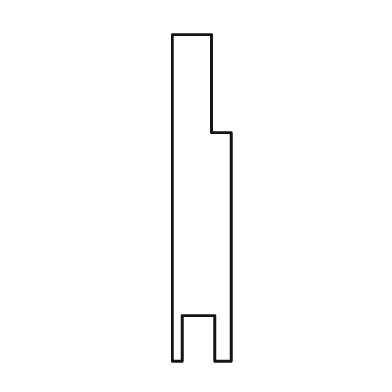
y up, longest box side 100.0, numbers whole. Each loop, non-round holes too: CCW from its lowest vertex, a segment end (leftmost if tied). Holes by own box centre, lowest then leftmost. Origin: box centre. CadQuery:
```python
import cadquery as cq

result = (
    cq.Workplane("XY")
    .moveTo(-9.0, -50.0)
    .lineTo(-6.0, -50.0)
    .lineTo(-6.0, -36.0)
    .lineTo(4.0, -36.0)
    .lineTo(4.0, -50.0)
    .lineTo(9.0, -50.0)
    .lineTo(9.0, 20.0)
    .lineTo(3.0, 20.0)
    .lineTo(3.0, 50.0)
    .lineTo(-9.0, 50.0)
    .close()
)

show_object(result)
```